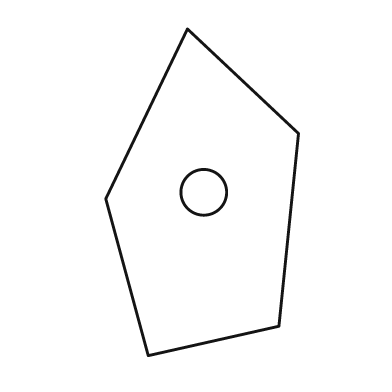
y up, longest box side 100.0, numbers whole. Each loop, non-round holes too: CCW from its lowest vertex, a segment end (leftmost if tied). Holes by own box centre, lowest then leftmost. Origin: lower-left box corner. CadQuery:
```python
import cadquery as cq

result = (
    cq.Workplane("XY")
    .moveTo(13.0, 0.0)
    .lineTo(53.0, 9.0)
    .lineTo(59.0, 68.0)
    .lineTo(25.0, 100.0)
    .lineTo(0.0, 48.0)
    .close()
    .moveTo(30.0, 50.0)
    .circle(7.0)
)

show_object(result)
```